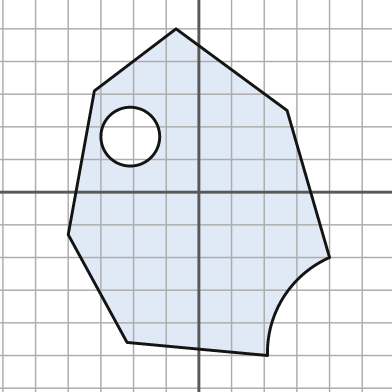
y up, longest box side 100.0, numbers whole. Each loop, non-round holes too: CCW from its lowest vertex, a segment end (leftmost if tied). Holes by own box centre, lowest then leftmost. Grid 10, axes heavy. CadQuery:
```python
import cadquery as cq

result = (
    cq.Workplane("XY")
    .moveTo(21.0, -50.0)
    .threePointArc((26.0, -32.0), (40.0, -20.0))
    .lineTo(27.0, 25.0)
    .lineTo(-7.0, 50.0)
    .lineTo(-32.0, 31.0)
    .lineTo(-40.0, -13.0)
    .lineTo(-22.0, -46.0)
    .close()
    .moveTo(-21.0, 17.0)
    .circle(9.0)
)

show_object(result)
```